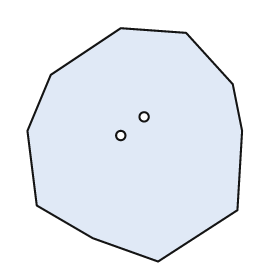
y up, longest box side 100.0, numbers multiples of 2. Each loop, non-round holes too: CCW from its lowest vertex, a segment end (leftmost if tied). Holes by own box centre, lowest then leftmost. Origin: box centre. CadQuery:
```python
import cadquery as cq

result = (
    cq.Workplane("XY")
    .moveTo(10.0, -50.0)
    .lineTo(44.0, -28.0)
    .lineTo(46.0, 6.0)
    .lineTo(42.0, 26.0)
    .lineTo(22.0, 48.0)
    .lineTo(-6.0, 50.0)
    .lineTo(-36.0, 30.0)
    .lineTo(-46.0, 6.0)
    .lineTo(-42.0, -26.0)
    .lineTo(-18.0, -40.0)
    .close()
    .moveTo(-6.0, 4.0)
    .circle(2.0)
    .moveTo(4.0, 12.0)
    .circle(2.0)
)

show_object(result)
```